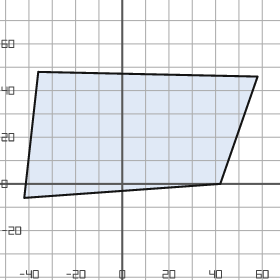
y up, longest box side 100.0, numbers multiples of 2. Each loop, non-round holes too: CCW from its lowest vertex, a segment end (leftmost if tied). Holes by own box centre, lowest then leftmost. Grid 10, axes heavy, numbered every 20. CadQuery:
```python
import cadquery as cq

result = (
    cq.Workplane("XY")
    .moveTo(-42.0, -6.0)
    .lineTo(42.0, 0.0)
    .lineTo(58.0, 46.0)
    .lineTo(-36.0, 48.0)
    .close()
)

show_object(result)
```